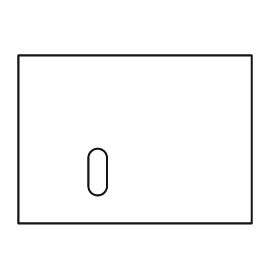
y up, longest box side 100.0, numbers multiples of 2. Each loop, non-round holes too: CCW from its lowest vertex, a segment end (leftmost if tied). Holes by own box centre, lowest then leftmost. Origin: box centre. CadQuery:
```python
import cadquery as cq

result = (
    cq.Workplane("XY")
    .moveTo(-50.0, -36.0)
    .lineTo(50.0, -36.0)
    .lineTo(50.0, 36.0)
    .lineTo(-50.0, 36.0)
    .close()
    .moveTo(-20.0, -20.0)
    .threePointArc((-16.0, -24.0), (-12.0, -20.0))
    .lineTo(-12.0, -8.0)
    .threePointArc((-16.0, -4.0), (-20.0, -8.0))
    .close()
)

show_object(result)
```